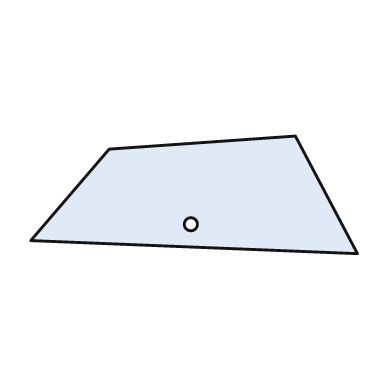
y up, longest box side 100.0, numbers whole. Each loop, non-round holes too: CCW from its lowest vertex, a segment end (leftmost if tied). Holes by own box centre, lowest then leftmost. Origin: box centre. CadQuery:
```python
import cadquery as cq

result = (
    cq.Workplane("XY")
    .moveTo(50.0, -18.0)
    .lineTo(31.0, 18.0)
    .lineTo(-26.0, 14.0)
    .lineTo(-50.0, -14.0)
    .close()
    .moveTo(-1.0, -9.0)
    .circle(2.0)
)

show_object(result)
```